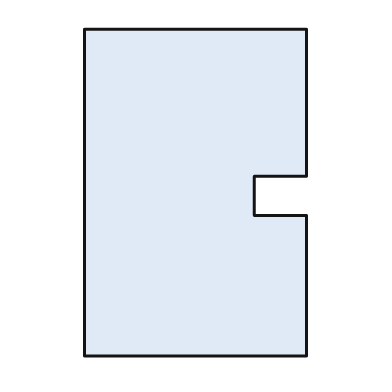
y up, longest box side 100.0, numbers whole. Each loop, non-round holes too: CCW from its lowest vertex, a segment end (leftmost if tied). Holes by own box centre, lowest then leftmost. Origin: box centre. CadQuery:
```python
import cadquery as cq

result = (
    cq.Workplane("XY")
    .moveTo(-34.0, -50.0)
    .lineTo(34.0, -50.0)
    .lineTo(34.0, -7.0)
    .lineTo(18.0, -7.0)
    .lineTo(18.0, 5.0)
    .lineTo(34.0, 5.0)
    .lineTo(34.0, 50.0)
    .lineTo(-34.0, 50.0)
    .close()
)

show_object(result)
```